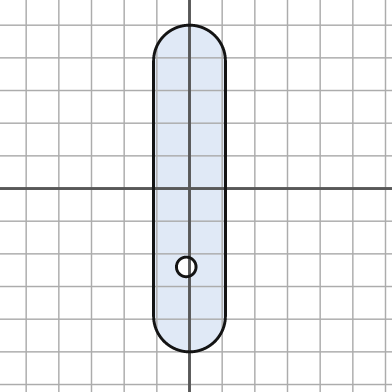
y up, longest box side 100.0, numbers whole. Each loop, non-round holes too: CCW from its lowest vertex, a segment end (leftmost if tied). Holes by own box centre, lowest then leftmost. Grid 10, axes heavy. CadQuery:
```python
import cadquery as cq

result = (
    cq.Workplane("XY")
    .moveTo(-11.0, -39.0)
    .threePointArc((0.0, -50.0), (11.0, -39.0))
    .lineTo(11.0, 39.0)
    .threePointArc((0.0, 50.0), (-11.0, 39.0))
    .close()
    .moveTo(-1.0, -24.0)
    .circle(3.0)
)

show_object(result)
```